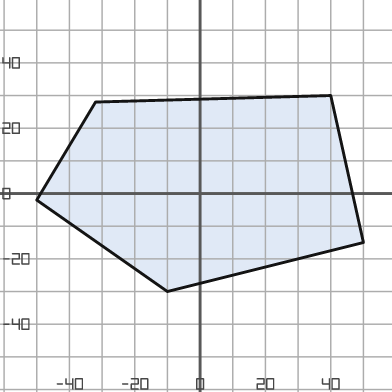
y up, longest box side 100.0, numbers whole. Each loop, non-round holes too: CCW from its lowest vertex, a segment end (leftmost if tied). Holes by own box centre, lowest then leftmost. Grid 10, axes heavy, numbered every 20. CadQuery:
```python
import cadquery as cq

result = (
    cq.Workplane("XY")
    .moveTo(-10.0, -30.0)
    .lineTo(50.0, -15.0)
    .lineTo(40.0, 30.0)
    .lineTo(-32.0, 28.0)
    .lineTo(-50.0, -2.0)
    .close()
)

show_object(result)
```